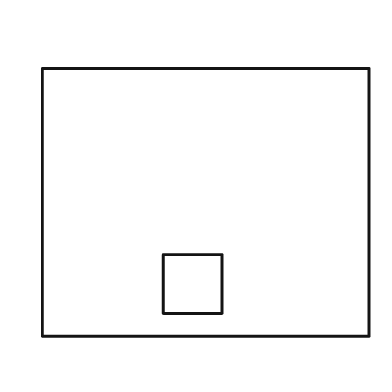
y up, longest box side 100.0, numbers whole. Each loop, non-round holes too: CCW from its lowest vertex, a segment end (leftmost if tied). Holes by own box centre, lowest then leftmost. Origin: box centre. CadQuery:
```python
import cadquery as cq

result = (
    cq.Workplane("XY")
    .moveTo(-50.0, -41.0)
    .lineTo(50.0, -41.0)
    .lineTo(50.0, 41.0)
    .lineTo(-50.0, 41.0)
    .close()
    .moveTo(-13.0, -34.0)
    .lineTo(5.0, -34.0)
    .lineTo(5.0, -16.0)
    .lineTo(-13.0, -16.0)
    .close()
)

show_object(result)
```